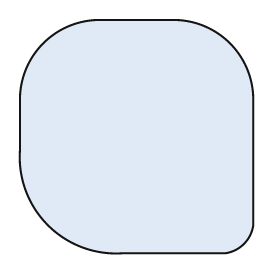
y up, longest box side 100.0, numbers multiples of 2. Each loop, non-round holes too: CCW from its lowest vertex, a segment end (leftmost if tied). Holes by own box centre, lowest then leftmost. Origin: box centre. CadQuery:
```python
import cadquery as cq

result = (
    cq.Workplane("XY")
    .moveTo(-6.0, -50.0)
    .lineTo(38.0, -50.0)
    .threePointArc((46.0, -46.0), (50.0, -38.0))
    .lineTo(50.0, 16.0)
    .threePointArc((40.0, 40.0), (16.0, 50.0))
    .lineTo(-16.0, 50.0)
    .threePointArc((-40.0, 40.0), (-50.0, 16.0))
    .lineTo(-50.0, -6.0)
    .threePointArc((-38.0, -38.0), (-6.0, -50.0))
    .close()
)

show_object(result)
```